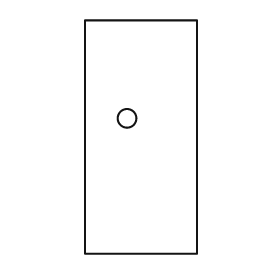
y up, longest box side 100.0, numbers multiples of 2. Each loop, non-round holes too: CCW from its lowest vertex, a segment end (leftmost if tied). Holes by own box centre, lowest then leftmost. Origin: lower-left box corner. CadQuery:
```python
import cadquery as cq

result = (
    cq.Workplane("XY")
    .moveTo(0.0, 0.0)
    .lineTo(48.0, 0.0)
    .lineTo(48.0, 100.0)
    .lineTo(0.0, 100.0)
    .close()
    .moveTo(18.0, 58.0)
    .circle(4.0)
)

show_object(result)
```